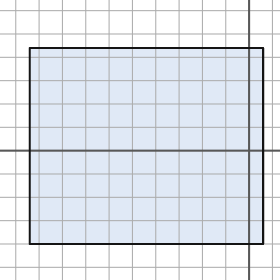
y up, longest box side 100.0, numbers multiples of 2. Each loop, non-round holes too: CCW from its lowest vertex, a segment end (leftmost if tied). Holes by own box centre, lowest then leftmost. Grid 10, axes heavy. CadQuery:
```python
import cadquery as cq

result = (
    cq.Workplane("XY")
    .moveTo(-94.0, -40.0)
    .lineTo(6.0, -40.0)
    .lineTo(6.0, 44.0)
    .lineTo(-94.0, 44.0)
    .close()
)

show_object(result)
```